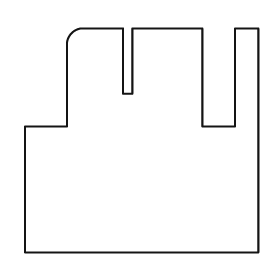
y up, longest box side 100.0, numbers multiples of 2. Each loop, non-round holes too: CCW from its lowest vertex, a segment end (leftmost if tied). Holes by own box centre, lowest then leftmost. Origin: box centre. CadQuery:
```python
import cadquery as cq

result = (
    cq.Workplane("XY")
    .moveTo(-50.0, -48.0)
    .lineTo(50.0, -48.0)
    .lineTo(50.0, 48.0)
    .lineTo(40.0, 48.0)
    .lineTo(40.0, 6.0)
    .lineTo(26.0, 6.0)
    .lineTo(26.0, 48.0)
    .lineTo(-4.0, 48.0)
    .lineTo(-4.0, 20.0)
    .lineTo(-8.0, 20.0)
    .lineTo(-8.0, 48.0)
    .lineTo(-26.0, 48.0)
    .threePointArc((-30.0, 46.0), (-32.0, 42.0))
    .lineTo(-32.0, 6.0)
    .lineTo(-50.0, 6.0)
    .close()
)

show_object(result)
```